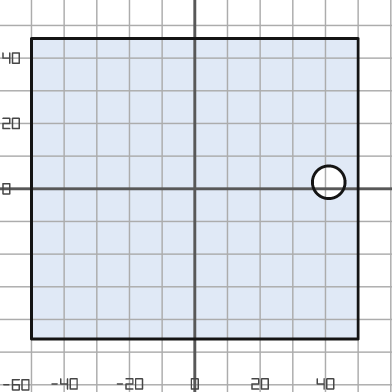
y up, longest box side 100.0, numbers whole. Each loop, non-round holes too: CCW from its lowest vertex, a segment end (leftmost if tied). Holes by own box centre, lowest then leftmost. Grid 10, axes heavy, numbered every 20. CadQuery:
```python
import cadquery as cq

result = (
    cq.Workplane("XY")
    .moveTo(-50.0, -46.0)
    .lineTo(50.0, -46.0)
    .lineTo(50.0, 46.0)
    .lineTo(-50.0, 46.0)
    .close()
    .moveTo(41.0, 2.0)
    .circle(5.0)
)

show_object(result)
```